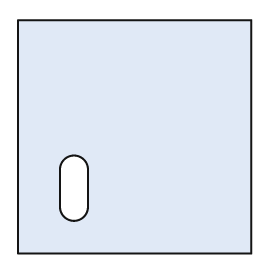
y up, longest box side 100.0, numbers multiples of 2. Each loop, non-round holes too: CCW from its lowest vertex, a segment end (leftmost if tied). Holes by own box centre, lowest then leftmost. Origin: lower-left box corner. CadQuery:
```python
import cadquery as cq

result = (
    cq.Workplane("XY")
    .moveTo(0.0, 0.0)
    .lineTo(100.0, 0.0)
    .lineTo(100.0, 100.0)
    .lineTo(0.0, 100.0)
    .close()
    .moveTo(18.0, 20.0)
    .threePointArc((24.0, 14.0), (30.0, 20.0))
    .lineTo(30.0, 36.0)
    .threePointArc((24.0, 42.0), (18.0, 36.0))
    .close()
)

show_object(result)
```